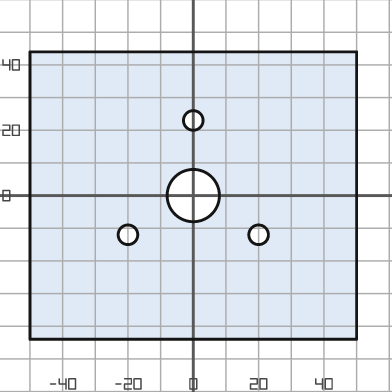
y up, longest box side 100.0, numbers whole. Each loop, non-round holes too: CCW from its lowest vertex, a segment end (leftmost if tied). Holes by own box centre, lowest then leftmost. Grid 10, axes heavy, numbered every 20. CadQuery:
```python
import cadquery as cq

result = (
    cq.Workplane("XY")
    .moveTo(-50.0, -44.0)
    .lineTo(50.0, -44.0)
    .lineTo(50.0, 44.0)
    .lineTo(-50.0, 44.0)
    .close()
    .moveTo(-20.0, -12.0)
    .circle(3.0)
    .moveTo(20.0, -12.0)
    .circle(3.0)
    .moveTo(0.0, 0.0)
    .circle(8.0)
    .moveTo(0.0, 23.0)
    .circle(3.0)
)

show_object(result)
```